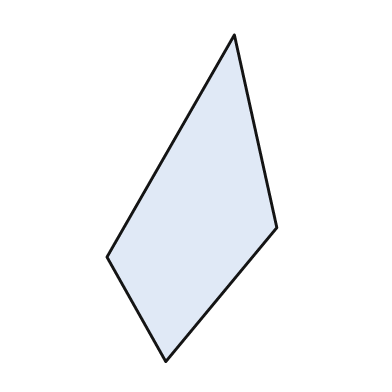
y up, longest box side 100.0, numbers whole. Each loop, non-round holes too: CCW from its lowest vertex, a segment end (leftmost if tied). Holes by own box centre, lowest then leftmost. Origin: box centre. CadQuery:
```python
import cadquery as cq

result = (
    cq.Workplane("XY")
    .moveTo(-8.0, -50.0)
    .lineTo(26.0, -9.0)
    .lineTo(13.0, 50.0)
    .lineTo(-26.0, -18.0)
    .close()
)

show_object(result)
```